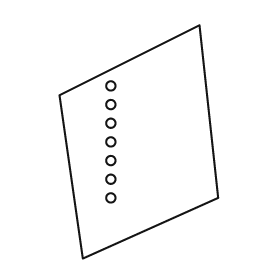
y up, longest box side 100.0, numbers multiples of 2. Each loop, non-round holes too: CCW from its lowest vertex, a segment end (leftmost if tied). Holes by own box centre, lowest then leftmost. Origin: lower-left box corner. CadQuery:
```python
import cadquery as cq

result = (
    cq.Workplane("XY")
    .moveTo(10.0, 0.0)
    .lineTo(68.0, 26.0)
    .lineTo(60.0, 100.0)
    .lineTo(0.0, 70.0)
    .close()
    .moveTo(22.0, 26.0)
    .circle(2.0)
    .moveTo(22.0, 34.0)
    .circle(2.0)
    .moveTo(22.0, 42.0)
    .circle(2.0)
    .moveTo(22.0, 50.0)
    .circle(2.0)
    .moveTo(22.0, 58.0)
    .circle(2.0)
    .moveTo(22.0, 66.0)
    .circle(2.0)
    .moveTo(22.0, 74.0)
    .circle(2.0)
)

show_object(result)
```